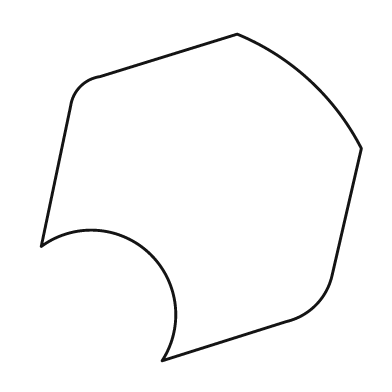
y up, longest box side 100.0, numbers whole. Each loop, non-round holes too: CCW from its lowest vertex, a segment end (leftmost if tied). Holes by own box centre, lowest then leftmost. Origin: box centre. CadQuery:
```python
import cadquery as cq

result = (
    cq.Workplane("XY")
    .moveTo(-12.0, -50.0)
    .lineTo(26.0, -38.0)
    .threePointArc((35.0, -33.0), (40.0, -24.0))
    .lineTo(49.0, 15.0)
    .threePointArc((33.0, 36.0), (11.0, 50.0))
    .lineTo(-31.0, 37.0)
    .threePointArc((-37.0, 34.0), (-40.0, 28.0))
    .lineTo(-49.0, -15.0)
    .threePointArc((-16.0, -17.0), (-12.0, -50.0))
    .close()
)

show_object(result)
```